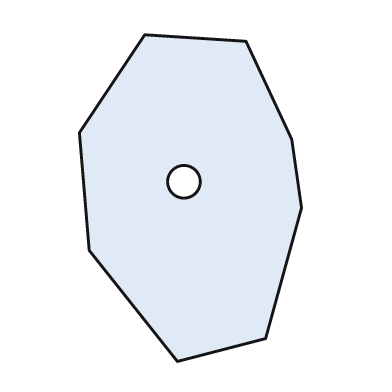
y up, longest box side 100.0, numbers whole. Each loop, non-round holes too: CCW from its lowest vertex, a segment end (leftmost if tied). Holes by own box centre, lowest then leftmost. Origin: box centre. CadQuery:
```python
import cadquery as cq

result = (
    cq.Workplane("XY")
    .moveTo(-4.0, -50.0)
    .lineTo(23.0, -43.0)
    .lineTo(34.0, -3.0)
    .lineTo(31.0, 18.0)
    .lineTo(17.0, 48.0)
    .lineTo(-14.0, 50.0)
    .lineTo(-34.0, 20.0)
    .lineTo(-31.0, -16.0)
    .close()
    .moveTo(-2.0, 5.0)
    .circle(5.0)
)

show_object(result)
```